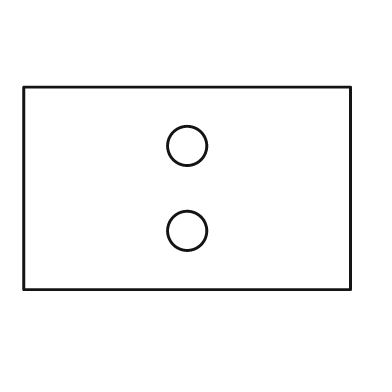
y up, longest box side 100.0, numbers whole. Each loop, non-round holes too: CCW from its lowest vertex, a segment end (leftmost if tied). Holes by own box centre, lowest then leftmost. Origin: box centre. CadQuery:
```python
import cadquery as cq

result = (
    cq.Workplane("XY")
    .moveTo(-50.0, -31.0)
    .lineTo(50.0, -31.0)
    .lineTo(50.0, 31.0)
    .lineTo(-50.0, 31.0)
    .close()
    .moveTo(0.0, -13.0)
    .circle(6.0)
    .moveTo(0.0, 13.0)
    .circle(6.0)
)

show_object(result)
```